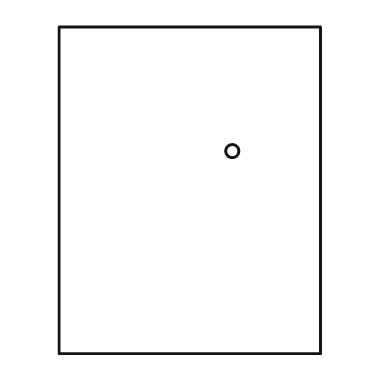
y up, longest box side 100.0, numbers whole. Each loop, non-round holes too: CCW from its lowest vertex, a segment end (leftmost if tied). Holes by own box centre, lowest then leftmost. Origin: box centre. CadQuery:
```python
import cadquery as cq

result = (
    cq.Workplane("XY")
    .moveTo(-40.0, -50.0)
    .lineTo(40.0, -50.0)
    .lineTo(40.0, 50.0)
    .lineTo(-40.0, 50.0)
    .close()
    .moveTo(13.0, 12.0)
    .circle(2.0)
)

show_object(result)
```